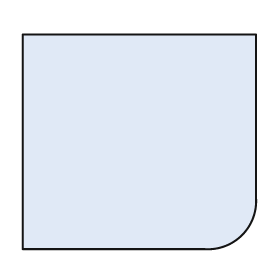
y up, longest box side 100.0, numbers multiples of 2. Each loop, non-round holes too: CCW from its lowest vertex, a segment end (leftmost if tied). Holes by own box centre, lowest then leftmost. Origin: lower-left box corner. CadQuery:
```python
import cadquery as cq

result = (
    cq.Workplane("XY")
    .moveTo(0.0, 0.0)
    .lineTo(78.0, 0.0)
    .threePointArc((94.0, 6.0), (100.0, 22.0))
    .lineTo(100.0, 92.0)
    .lineTo(0.0, 92.0)
    .close()
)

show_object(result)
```